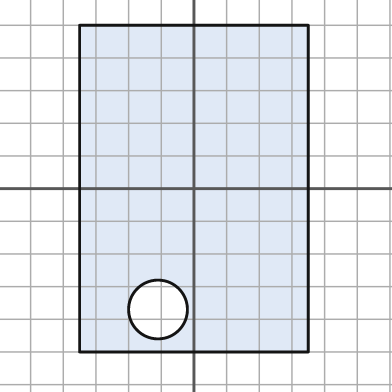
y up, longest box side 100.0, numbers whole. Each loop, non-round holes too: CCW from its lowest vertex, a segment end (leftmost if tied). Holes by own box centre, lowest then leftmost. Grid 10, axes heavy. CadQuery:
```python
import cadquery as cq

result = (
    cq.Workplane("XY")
    .moveTo(-35.0, -50.0)
    .lineTo(35.0, -50.0)
    .lineTo(35.0, 50.0)
    .lineTo(-35.0, 50.0)
    .close()
    .moveTo(-11.0, -37.0)
    .circle(9.0)
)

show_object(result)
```